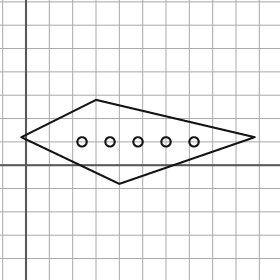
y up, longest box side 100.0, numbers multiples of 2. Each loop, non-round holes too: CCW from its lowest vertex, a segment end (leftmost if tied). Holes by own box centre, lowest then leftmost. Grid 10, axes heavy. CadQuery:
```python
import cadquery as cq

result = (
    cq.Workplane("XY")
    .moveTo(40.0, -8.0)
    .lineTo(98.0, 12.0)
    .lineTo(30.0, 28.0)
    .lineTo(-2.0, 12.0)
    .close()
    .moveTo(24.0, 10.0)
    .circle(2.0)
    .moveTo(36.0, 10.0)
    .circle(2.0)
    .moveTo(48.0, 10.0)
    .circle(2.0)
    .moveTo(60.0, 10.0)
    .circle(2.0)
    .moveTo(72.0, 10.0)
    .circle(2.0)
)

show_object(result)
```